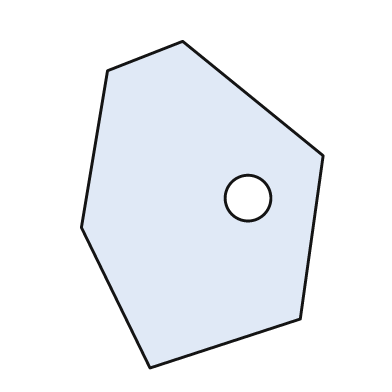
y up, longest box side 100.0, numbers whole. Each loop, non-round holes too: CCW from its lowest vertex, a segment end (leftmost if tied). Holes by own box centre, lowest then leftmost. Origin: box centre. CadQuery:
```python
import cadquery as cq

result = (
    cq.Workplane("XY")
    .moveTo(-16.0, -50.0)
    .lineTo(30.0, -35.0)
    .lineTo(37.0, 15.0)
    .lineTo(-6.0, 50.0)
    .lineTo(-29.0, 41.0)
    .lineTo(-37.0, -7.0)
    .close()
    .moveTo(14.0, 2.0)
    .circle(7.0)
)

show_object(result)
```